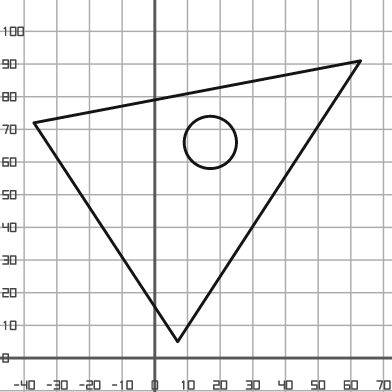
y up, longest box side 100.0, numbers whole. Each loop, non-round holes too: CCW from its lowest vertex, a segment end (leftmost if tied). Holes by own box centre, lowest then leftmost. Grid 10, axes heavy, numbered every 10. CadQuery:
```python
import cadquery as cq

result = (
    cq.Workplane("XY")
    .moveTo(7.0, 5.0)
    .lineTo(63.0, 91.0)
    .lineTo(-37.0, 72.0)
    .close()
    .moveTo(17.0, 66.0)
    .circle(8.0)
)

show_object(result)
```